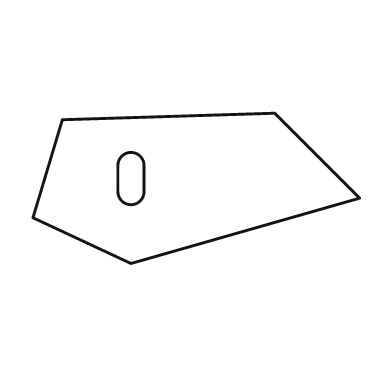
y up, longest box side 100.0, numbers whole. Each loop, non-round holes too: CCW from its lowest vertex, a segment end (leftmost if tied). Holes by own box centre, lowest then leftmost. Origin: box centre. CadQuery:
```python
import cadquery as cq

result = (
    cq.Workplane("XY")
    .moveTo(-20.0, -23.0)
    .lineTo(50.0, -3.0)
    .lineTo(24.0, 23.0)
    .lineTo(-41.0, 21.0)
    .lineTo(-50.0, -9.0)
    .close()
    .moveTo(-24.0, -1.0)
    .threePointArc((-20.0, -5.0), (-16.0, -1.0))
    .lineTo(-16.0, 7.0)
    .threePointArc((-20.0, 11.0), (-24.0, 7.0))
    .close()
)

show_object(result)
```